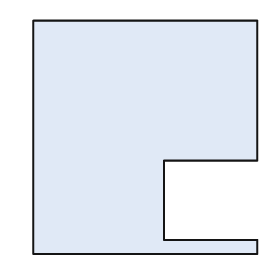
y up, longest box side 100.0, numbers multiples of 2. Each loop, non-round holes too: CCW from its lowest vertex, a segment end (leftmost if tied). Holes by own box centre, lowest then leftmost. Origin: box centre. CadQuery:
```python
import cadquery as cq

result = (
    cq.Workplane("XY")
    .moveTo(-48.0, -50.0)
    .lineTo(48.0, -50.0)
    .lineTo(48.0, -44.0)
    .lineTo(8.0, -44.0)
    .lineTo(8.0, -10.0)
    .lineTo(48.0, -10.0)
    .lineTo(48.0, 50.0)
    .lineTo(-48.0, 50.0)
    .close()
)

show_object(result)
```